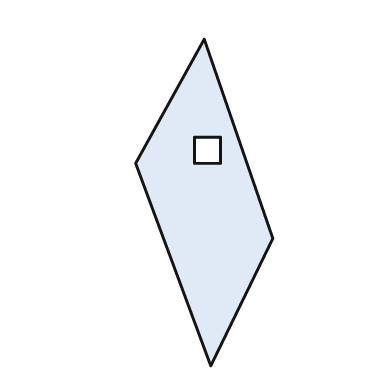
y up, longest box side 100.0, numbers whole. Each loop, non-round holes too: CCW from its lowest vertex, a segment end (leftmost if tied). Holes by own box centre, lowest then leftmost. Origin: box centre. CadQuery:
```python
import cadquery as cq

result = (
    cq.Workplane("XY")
    .moveTo(2.0, -50.0)
    .lineTo(21.0, -11.0)
    .lineTo(0.0, 50.0)
    .lineTo(-21.0, 12.0)
    .close()
    .moveTo(-3.0, 12.0)
    .lineTo(5.0, 12.0)
    .lineTo(5.0, 20.0)
    .lineTo(-3.0, 20.0)
    .close()
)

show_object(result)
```